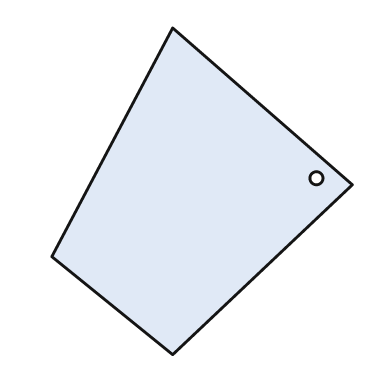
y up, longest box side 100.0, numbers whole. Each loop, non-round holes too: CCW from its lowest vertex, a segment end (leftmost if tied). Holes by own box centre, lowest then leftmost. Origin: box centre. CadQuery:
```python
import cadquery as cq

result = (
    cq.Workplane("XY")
    .moveTo(-9.0, -50.0)
    .lineTo(46.0, 2.0)
    .lineTo(-9.0, 50.0)
    .lineTo(-46.0, -20.0)
    .close()
    .moveTo(35.0, 4.0)
    .circle(2.0)
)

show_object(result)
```